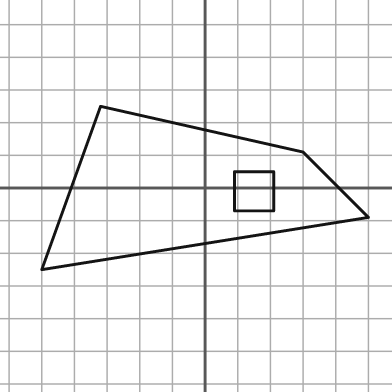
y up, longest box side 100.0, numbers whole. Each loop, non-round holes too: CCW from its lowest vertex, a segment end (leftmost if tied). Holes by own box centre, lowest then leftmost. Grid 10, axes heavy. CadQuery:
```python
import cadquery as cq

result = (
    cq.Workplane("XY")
    .moveTo(-50.0, -25.0)
    .lineTo(50.0, -9.0)
    .lineTo(30.0, 11.0)
    .lineTo(-32.0, 25.0)
    .close()
    .moveTo(9.0, -7.0)
    .lineTo(21.0, -7.0)
    .lineTo(21.0, 5.0)
    .lineTo(9.0, 5.0)
    .close()
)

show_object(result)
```